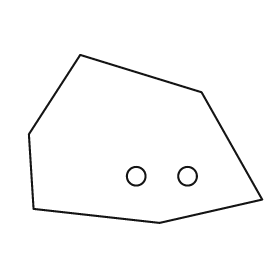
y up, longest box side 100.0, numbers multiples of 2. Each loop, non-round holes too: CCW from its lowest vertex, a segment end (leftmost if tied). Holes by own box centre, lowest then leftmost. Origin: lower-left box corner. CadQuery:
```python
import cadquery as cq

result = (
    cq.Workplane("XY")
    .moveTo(56.0, 0.0)
    .lineTo(100.0, 10.0)
    .lineTo(74.0, 56.0)
    .lineTo(22.0, 72.0)
    .lineTo(0.0, 38.0)
    .lineTo(2.0, 6.0)
    .close()
    .moveTo(46.0, 20.0)
    .circle(4.0)
    .moveTo(68.0, 20.0)
    .circle(4.0)
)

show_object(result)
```